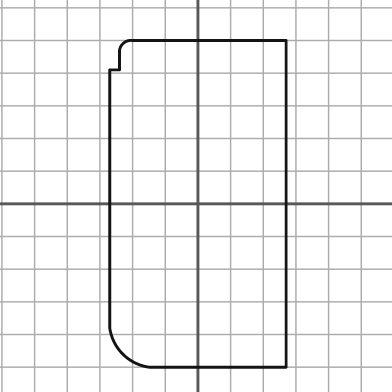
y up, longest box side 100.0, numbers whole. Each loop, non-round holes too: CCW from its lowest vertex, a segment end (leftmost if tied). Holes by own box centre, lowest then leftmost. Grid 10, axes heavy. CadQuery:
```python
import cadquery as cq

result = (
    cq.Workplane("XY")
    .moveTo(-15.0, -50.0)
    .lineTo(27.0, -50.0)
    .lineTo(27.0, 50.0)
    .lineTo(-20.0, 50.0)
    .threePointArc((-23.0, 49.0), (-24.0, 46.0))
    .lineTo(-24.0, 41.0)
    .lineTo(-27.0, 41.0)
    .lineTo(-27.0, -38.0)
    .threePointArc((-23.0, -46.0), (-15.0, -50.0))
    .close()
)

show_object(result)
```